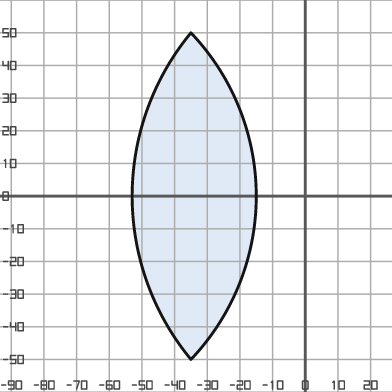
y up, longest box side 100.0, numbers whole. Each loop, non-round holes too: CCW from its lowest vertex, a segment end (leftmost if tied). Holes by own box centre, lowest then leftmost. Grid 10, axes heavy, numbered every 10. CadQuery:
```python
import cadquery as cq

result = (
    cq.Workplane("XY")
    .moveTo(-35.0, -50.0)
    .threePointArc((-15.0, 0.0), (-35.0, 50.0))
    .threePointArc((-53.0, 0.0), (-35.0, -50.0))
    .close()
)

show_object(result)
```